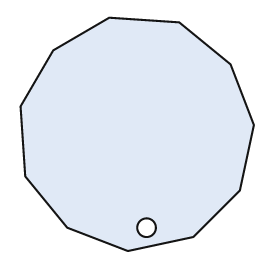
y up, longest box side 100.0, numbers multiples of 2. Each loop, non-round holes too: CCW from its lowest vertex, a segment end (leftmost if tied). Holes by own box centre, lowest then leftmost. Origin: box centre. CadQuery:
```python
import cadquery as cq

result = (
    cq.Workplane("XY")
    .moveTo(-4.0, -50.0)
    .lineTo(24.0, -44.0)
    .lineTo(44.0, -24.0)
    .lineTo(50.0, 4.0)
    .lineTo(40.0, 30.0)
    .lineTo(18.0, 48.0)
    .lineTo(-12.0, 50.0)
    .lineTo(-36.0, 36.0)
    .lineTo(-50.0, 12.0)
    .lineTo(-48.0, -18.0)
    .lineTo(-30.0, -40.0)
    .close()
    .moveTo(4.0, -40.0)
    .circle(4.0)
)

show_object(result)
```